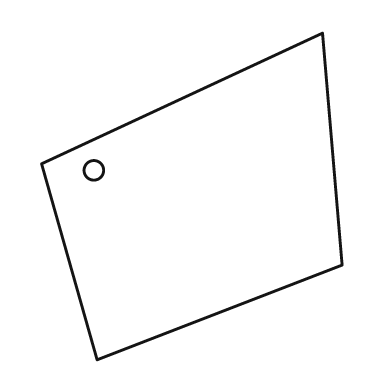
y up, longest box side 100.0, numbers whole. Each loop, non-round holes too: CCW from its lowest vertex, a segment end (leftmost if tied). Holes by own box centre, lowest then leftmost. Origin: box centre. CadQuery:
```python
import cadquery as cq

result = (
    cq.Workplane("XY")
    .moveTo(-29.0, -50.0)
    .lineTo(46.0, -21.0)
    .lineTo(40.0, 50.0)
    .lineTo(-46.0, 10.0)
    .close()
    .moveTo(-30.0, 8.0)
    .circle(3.0)
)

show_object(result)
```